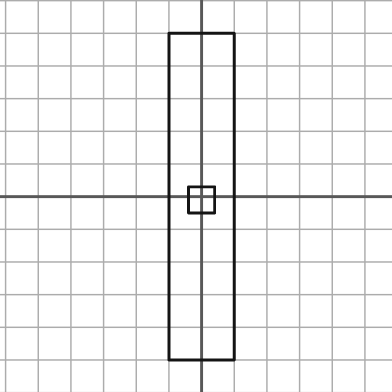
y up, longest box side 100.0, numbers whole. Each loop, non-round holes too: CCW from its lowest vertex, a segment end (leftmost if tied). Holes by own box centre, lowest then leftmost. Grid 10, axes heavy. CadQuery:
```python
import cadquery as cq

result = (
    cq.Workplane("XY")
    .moveTo(-10.0, -50.0)
    .lineTo(10.0, -50.0)
    .lineTo(10.0, 50.0)
    .lineTo(-10.0, 50.0)
    .close()
    .moveTo(-4.0, -5.0)
    .lineTo(4.0, -5.0)
    .lineTo(4.0, 3.0)
    .lineTo(-4.0, 3.0)
    .close()
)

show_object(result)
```